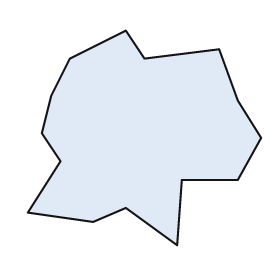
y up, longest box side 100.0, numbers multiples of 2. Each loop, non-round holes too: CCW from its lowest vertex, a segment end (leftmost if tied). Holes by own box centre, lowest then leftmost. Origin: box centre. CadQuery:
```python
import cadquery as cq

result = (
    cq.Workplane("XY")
    .moveTo(14.0, -46.0)
    .lineTo(16.0, -18.0)
    .lineTo(40.0, -18.0)
    .lineTo(50.0, 0.0)
    .lineTo(40.0, 16.0)
    .lineTo(32.0, 38.0)
    .lineTo(0.0, 34.0)
    .lineTo(-8.0, 46.0)
    .lineTo(-32.0, 34.0)
    .lineTo(-40.0, 18.0)
    .lineTo(-44.0, 2.0)
    .lineTo(-36.0, -10.0)
    .lineTo(-50.0, -32.0)
    .lineTo(-22.0, -36.0)
    .lineTo(-8.0, -30.0)
    .close()
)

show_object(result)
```